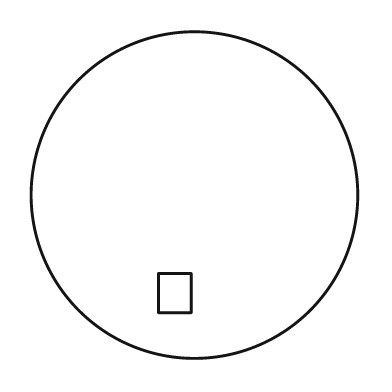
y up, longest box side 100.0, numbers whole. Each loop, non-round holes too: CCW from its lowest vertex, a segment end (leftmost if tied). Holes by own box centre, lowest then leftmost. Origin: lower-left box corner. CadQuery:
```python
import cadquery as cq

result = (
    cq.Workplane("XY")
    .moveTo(50.0, 50.0)
    .circle(50.0)
    .moveTo(39.0, 14.0)
    .lineTo(49.0, 14.0)
    .lineTo(49.0, 26.0)
    .lineTo(39.0, 26.0)
    .close()
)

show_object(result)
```